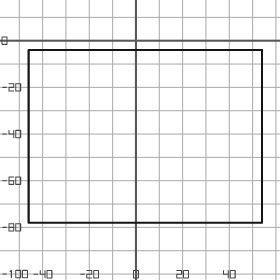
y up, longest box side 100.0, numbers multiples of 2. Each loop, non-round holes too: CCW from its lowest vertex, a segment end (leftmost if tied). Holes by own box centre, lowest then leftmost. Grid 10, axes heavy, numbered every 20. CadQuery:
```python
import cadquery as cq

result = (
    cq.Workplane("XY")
    .moveTo(-46.0, -78.0)
    .lineTo(54.0, -78.0)
    .lineTo(54.0, -4.0)
    .lineTo(-46.0, -4.0)
    .close()
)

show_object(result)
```